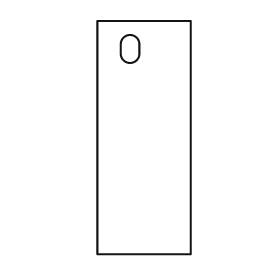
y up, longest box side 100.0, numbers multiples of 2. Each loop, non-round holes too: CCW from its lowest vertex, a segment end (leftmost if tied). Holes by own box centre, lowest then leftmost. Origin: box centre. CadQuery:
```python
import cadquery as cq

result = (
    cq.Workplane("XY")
    .moveTo(-20.0, -50.0)
    .lineTo(20.0, -50.0)
    .lineTo(20.0, 50.0)
    .lineTo(-20.0, 50.0)
    .close()
    .moveTo(-10.0, 36.0)
    .threePointArc((-6.0, 32.0), (-2.0, 36.0))
    .lineTo(-2.0, 40.0)
    .threePointArc((-6.0, 44.0), (-10.0, 40.0))
    .close()
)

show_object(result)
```